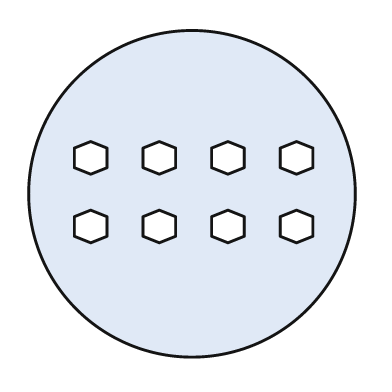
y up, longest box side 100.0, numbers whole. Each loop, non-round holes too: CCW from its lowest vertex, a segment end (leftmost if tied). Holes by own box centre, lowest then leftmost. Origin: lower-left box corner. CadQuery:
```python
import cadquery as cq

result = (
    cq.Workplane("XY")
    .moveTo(50.0, 50.0)
    .circle(50.0)
    .moveTo(19.0, 35.0)
    .lineTo(24.0, 37.0)
    .lineTo(24.0, 43.0)
    .lineTo(19.0, 45.0)
    .lineTo(14.0, 43.0)
    .lineTo(14.0, 37.0)
    .close()
    .moveTo(40.0, 35.0)
    .lineTo(45.0, 37.0)
    .lineTo(45.0, 43.0)
    .lineTo(40.0, 45.0)
    .lineTo(35.0, 43.0)
    .lineTo(35.0, 37.0)
    .close()
    .moveTo(61.0, 35.0)
    .lineTo(66.0, 37.0)
    .lineTo(66.0, 43.0)
    .lineTo(61.0, 45.0)
    .lineTo(56.0, 43.0)
    .lineTo(56.0, 37.0)
    .close()
    .moveTo(82.0, 35.0)
    .lineTo(87.0, 37.0)
    .lineTo(87.0, 43.0)
    .lineTo(82.0, 45.0)
    .lineTo(77.0, 43.0)
    .lineTo(77.0, 37.0)
    .close()
    .moveTo(19.0, 56.0)
    .lineTo(24.0, 58.0)
    .lineTo(24.0, 64.0)
    .lineTo(19.0, 66.0)
    .lineTo(14.0, 64.0)
    .lineTo(14.0, 58.0)
    .close()
    .moveTo(40.0, 56.0)
    .lineTo(45.0, 58.0)
    .lineTo(45.0, 64.0)
    .lineTo(40.0, 66.0)
    .lineTo(35.0, 64.0)
    .lineTo(35.0, 58.0)
    .close()
    .moveTo(61.0, 56.0)
    .lineTo(66.0, 58.0)
    .lineTo(66.0, 64.0)
    .lineTo(61.0, 66.0)
    .lineTo(56.0, 64.0)
    .lineTo(56.0, 58.0)
    .close()
    .moveTo(82.0, 56.0)
    .lineTo(87.0, 58.0)
    .lineTo(87.0, 64.0)
    .lineTo(82.0, 66.0)
    .lineTo(77.0, 64.0)
    .lineTo(77.0, 58.0)
    .close()
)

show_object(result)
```